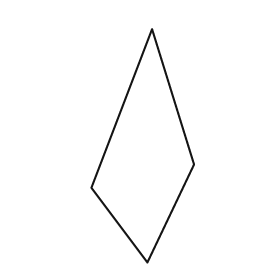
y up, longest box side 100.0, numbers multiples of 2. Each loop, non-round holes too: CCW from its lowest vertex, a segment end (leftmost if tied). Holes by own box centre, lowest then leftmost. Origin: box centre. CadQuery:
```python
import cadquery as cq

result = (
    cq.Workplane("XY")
    .moveTo(2.0, -50.0)
    .lineTo(22.0, -8.0)
    .lineTo(4.0, 50.0)
    .lineTo(-22.0, -18.0)
    .close()
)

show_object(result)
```